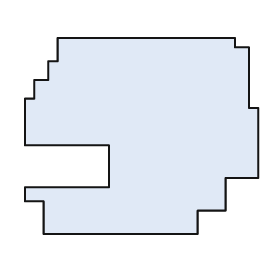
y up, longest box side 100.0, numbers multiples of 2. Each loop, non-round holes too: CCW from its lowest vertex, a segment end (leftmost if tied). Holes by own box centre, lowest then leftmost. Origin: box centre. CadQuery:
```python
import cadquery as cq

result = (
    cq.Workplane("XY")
    .moveTo(-42.0, -42.0)
    .lineTo(24.0, -42.0)
    .lineTo(24.0, -32.0)
    .lineTo(36.0, -32.0)
    .lineTo(36.0, -18.0)
    .lineTo(50.0, -18.0)
    .lineTo(50.0, 12.0)
    .lineTo(46.0, 12.0)
    .lineTo(46.0, 38.0)
    .lineTo(40.0, 38.0)
    .lineTo(40.0, 42.0)
    .lineTo(-36.0, 42.0)
    .lineTo(-36.0, 32.0)
    .lineTo(-40.0, 32.0)
    .lineTo(-40.0, 24.0)
    .lineTo(-46.0, 24.0)
    .lineTo(-46.0, 16.0)
    .lineTo(-50.0, 16.0)
    .lineTo(-50.0, -4.0)
    .lineTo(-14.0, -4.0)
    .lineTo(-14.0, -22.0)
    .lineTo(-50.0, -22.0)
    .lineTo(-50.0, -28.0)
    .lineTo(-42.0, -28.0)
    .close()
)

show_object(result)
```